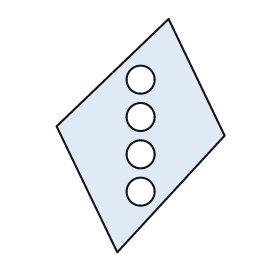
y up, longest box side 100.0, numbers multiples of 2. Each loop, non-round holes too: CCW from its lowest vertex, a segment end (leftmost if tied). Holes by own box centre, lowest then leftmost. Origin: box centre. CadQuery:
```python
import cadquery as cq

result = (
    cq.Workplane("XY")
    .moveTo(-10.0, -50.0)
    .lineTo(36.0, 0.0)
    .lineTo(12.0, 50.0)
    .lineTo(-36.0, 4.0)
    .close()
    .moveTo(0.0, -24.0)
    .circle(6.0)
    .moveTo(0.0, -8.0)
    .circle(6.0)
    .moveTo(0.0, 8.0)
    .circle(6.0)
    .moveTo(0.0, 24.0)
    .circle(6.0)
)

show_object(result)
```